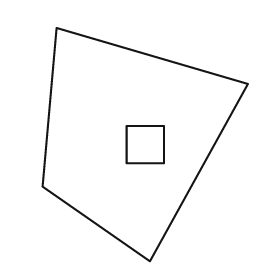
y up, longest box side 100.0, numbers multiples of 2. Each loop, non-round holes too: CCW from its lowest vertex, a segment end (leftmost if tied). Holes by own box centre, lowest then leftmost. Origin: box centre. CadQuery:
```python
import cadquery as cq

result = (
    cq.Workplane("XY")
    .moveTo(2.0, -50.0)
    .lineTo(44.0, 26.0)
    .lineTo(-38.0, 50.0)
    .lineTo(-44.0, -18.0)
    .close()
    .moveTo(-8.0, -8.0)
    .lineTo(8.0, -8.0)
    .lineTo(8.0, 8.0)
    .lineTo(-8.0, 8.0)
    .close()
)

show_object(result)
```